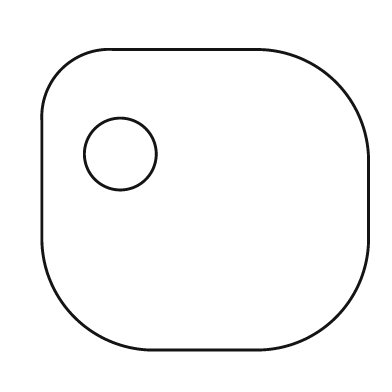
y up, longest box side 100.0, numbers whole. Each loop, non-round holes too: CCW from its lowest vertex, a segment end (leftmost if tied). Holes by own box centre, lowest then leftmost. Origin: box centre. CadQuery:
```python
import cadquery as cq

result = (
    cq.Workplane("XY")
    .moveTo(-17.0, -46.0)
    .lineTo(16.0, -46.0)
    .threePointArc((40.0, -36.0), (50.0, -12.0))
    .lineTo(50.0, 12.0)
    .threePointArc((40.0, 36.0), (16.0, 46.0))
    .lineTo(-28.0, 46.0)
    .threePointArc((-44.0, 40.0), (-50.0, 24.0))
    .lineTo(-50.0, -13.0)
    .threePointArc((-40.0, -36.0), (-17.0, -46.0))
    .close()
    .moveTo(-26.0, 14.0)
    .circle(11.0)
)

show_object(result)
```